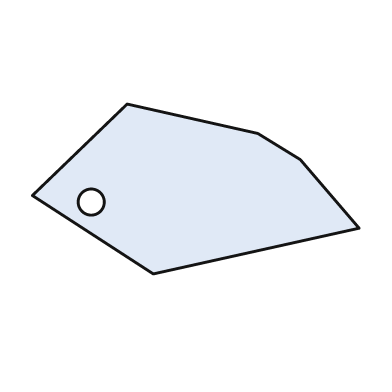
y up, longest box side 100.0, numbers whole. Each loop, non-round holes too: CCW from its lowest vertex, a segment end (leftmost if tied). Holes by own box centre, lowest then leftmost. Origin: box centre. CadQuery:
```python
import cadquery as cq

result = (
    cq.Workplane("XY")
    .moveTo(-13.0, -26.0)
    .lineTo(50.0, -12.0)
    .lineTo(32.0, 9.0)
    .lineTo(19.0, 17.0)
    .lineTo(-21.0, 26.0)
    .lineTo(-50.0, -2.0)
    .close()
    .moveTo(-32.0, -4.0)
    .circle(4.0)
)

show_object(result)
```